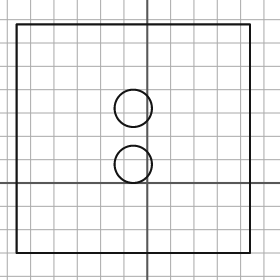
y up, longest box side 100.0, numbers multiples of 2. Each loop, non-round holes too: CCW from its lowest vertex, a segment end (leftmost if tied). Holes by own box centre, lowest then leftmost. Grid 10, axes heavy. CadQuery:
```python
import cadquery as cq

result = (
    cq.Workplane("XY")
    .moveTo(-56.0, -30.0)
    .lineTo(44.0, -30.0)
    .lineTo(44.0, 68.0)
    .lineTo(-56.0, 68.0)
    .close()
    .moveTo(-6.0, 8.0)
    .circle(8.0)
    .moveTo(-6.0, 32.0)
    .circle(8.0)
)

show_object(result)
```